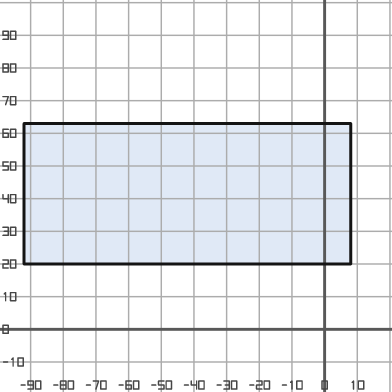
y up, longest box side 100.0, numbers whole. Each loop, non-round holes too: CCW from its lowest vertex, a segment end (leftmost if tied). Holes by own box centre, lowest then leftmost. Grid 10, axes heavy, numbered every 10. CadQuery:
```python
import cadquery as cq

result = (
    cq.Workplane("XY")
    .moveTo(-92.0, 20.0)
    .lineTo(8.0, 20.0)
    .lineTo(8.0, 63.0)
    .lineTo(-92.0, 63.0)
    .close()
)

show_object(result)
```